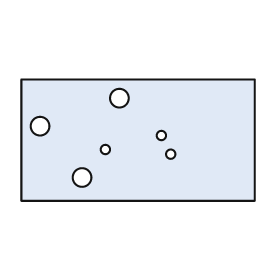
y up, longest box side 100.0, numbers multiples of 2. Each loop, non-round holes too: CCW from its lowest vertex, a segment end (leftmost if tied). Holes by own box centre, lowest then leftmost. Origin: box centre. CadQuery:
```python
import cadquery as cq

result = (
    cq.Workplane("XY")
    .moveTo(-50.0, -26.0)
    .lineTo(50.0, -26.0)
    .lineTo(50.0, 26.0)
    .lineTo(-50.0, 26.0)
    .close()
    .moveTo(-24.0, -16.0)
    .circle(4.0)
    .moveTo(14.0, -6.0)
    .circle(2.0)
    .moveTo(-14.0, -4.0)
    .circle(2.0)
    .moveTo(10.0, 2.0)
    .circle(2.0)
    .moveTo(-42.0, 6.0)
    .circle(4.0)
    .moveTo(-8.0, 18.0)
    .circle(4.0)
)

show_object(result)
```